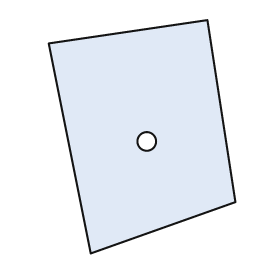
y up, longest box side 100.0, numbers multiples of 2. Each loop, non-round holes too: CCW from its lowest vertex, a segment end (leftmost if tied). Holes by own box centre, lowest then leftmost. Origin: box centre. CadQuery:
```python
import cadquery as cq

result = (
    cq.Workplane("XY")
    .moveTo(-22.0, -50.0)
    .lineTo(40.0, -28.0)
    .lineTo(28.0, 50.0)
    .lineTo(-40.0, 40.0)
    .close()
    .moveTo(2.0, -2.0)
    .circle(4.0)
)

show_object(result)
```